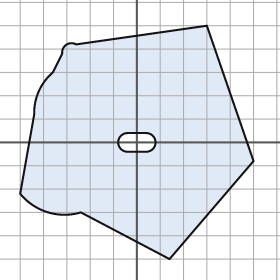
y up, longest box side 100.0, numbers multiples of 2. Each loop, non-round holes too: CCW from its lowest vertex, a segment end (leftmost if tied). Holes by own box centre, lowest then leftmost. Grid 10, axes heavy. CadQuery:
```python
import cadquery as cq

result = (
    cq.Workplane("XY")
    .moveTo(14.0, -50.0)
    .lineTo(50.0, -8.0)
    .lineTo(30.0, 50.0)
    .lineTo(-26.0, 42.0)
    .threePointArc((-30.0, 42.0), (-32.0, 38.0))
    .lineTo(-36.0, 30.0)
    .threePointArc((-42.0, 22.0), (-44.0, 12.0))
    .lineTo(-50.0, -22.0)
    .threePointArc((-38.0, -30.0), (-24.0, -30.0))
    .close()
    .moveTo(-4.0, -4.0)
    .lineTo(4.0, -4.0)
    .threePointArc((8.0, 0.0), (4.0, 4.0))
    .lineTo(-4.0, 4.0)
    .threePointArc((-8.0, 0.0), (-4.0, -4.0))
    .close()
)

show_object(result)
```